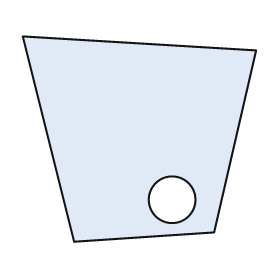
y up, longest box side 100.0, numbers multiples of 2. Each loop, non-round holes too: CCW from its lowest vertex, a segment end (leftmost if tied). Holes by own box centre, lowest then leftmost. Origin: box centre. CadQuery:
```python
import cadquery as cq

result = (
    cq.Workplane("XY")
    .moveTo(-28.0, -44.0)
    .lineTo(32.0, -40.0)
    .lineTo(50.0, 38.0)
    .lineTo(-50.0, 44.0)
    .close()
    .moveTo(14.0, -26.0)
    .circle(10.0)
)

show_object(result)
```